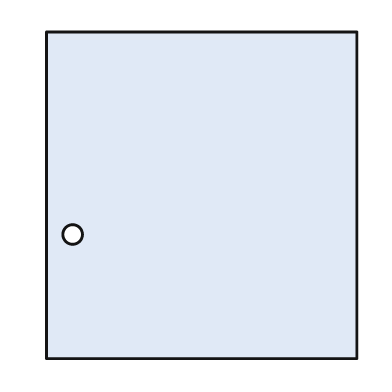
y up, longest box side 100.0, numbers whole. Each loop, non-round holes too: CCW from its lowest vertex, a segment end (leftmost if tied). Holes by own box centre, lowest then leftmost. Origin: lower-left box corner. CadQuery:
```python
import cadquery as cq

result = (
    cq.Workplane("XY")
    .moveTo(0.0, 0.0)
    .lineTo(95.0, 0.0)
    .lineTo(95.0, 100.0)
    .lineTo(0.0, 100.0)
    .close()
    .moveTo(8.0, 38.0)
    .circle(3.0)
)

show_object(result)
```